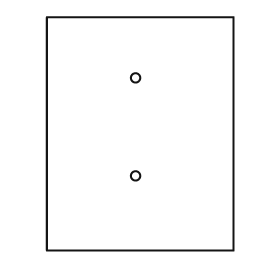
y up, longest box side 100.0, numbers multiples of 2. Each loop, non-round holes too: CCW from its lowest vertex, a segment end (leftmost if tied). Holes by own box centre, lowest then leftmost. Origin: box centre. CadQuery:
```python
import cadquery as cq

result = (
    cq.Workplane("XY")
    .moveTo(-40.0, -50.0)
    .lineTo(40.0, -50.0)
    .lineTo(40.0, 50.0)
    .lineTo(-40.0, 50.0)
    .close()
    .moveTo(-2.0, -18.0)
    .circle(2.0)
    .moveTo(-2.0, 24.0)
    .circle(2.0)
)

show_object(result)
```